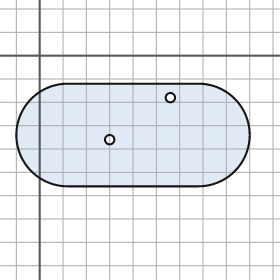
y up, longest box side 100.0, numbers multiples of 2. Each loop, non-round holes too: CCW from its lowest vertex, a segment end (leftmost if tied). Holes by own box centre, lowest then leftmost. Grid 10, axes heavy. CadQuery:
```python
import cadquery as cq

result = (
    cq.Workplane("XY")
    .moveTo(12.0, -56.0)
    .lineTo(68.0, -56.0)
    .threePointArc((90.0, -34.0), (68.0, -12.0))
    .lineTo(12.0, -12.0)
    .threePointArc((-10.0, -34.0), (12.0, -56.0))
    .close()
    .moveTo(30.0, -36.0)
    .circle(2.0)
    .moveTo(56.0, -18.0)
    .circle(2.0)
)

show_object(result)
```